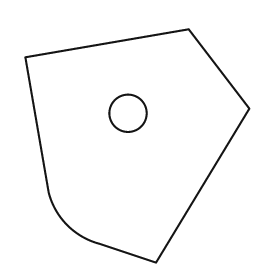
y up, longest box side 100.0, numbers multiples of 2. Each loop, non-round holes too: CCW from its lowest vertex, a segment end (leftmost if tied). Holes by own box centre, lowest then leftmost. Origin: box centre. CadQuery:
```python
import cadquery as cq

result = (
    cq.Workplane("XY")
    .moveTo(8.0, -50.0)
    .lineTo(48.0, 16.0)
    .lineTo(22.0, 50.0)
    .lineTo(-48.0, 38.0)
    .lineTo(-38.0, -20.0)
    .threePointArc((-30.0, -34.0), (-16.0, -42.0))
    .close()
    .moveTo(-4.0, 14.0)
    .circle(8.0)
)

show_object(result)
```